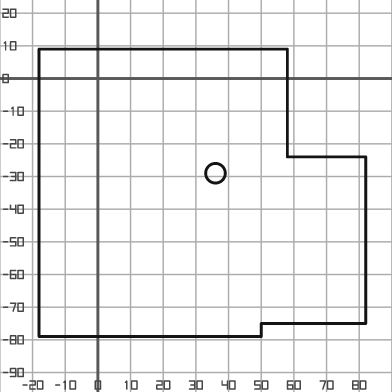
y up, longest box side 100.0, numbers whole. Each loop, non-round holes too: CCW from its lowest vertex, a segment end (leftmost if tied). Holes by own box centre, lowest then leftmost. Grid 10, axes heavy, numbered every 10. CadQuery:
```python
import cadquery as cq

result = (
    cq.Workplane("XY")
    .moveTo(-18.0, -79.0)
    .lineTo(50.0, -79.0)
    .lineTo(50.0, -75.0)
    .lineTo(82.0, -75.0)
    .lineTo(82.0, -24.0)
    .lineTo(58.0, -24.0)
    .lineTo(58.0, 9.0)
    .lineTo(-18.0, 9.0)
    .close()
    .moveTo(36.0, -29.0)
    .circle(3.0)
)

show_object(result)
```